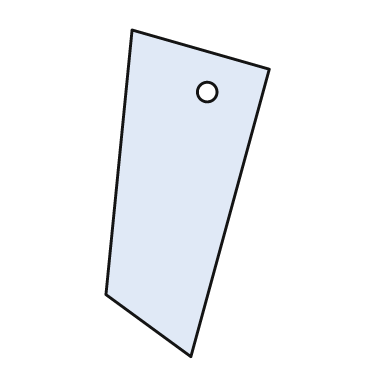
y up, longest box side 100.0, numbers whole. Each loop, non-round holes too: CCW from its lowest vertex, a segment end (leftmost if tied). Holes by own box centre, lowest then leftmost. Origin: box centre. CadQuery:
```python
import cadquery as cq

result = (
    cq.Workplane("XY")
    .moveTo(1.0, -50.0)
    .lineTo(25.0, 38.0)
    .lineTo(-17.0, 50.0)
    .lineTo(-25.0, -31.0)
    .close()
    .moveTo(6.0, 31.0)
    .circle(3.0)
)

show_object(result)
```